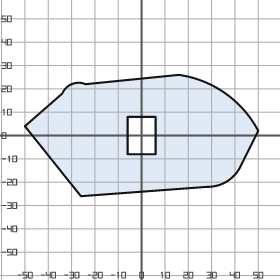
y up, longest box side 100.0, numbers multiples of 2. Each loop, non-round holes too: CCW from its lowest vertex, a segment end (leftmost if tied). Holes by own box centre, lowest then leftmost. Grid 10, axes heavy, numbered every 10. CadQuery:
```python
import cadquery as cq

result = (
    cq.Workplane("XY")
    .moveTo(-26.0, -26.0)
    .lineTo(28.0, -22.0)
    .threePointArc((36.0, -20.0), (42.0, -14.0))
    .lineTo(50.0, 2.0)
    .threePointArc((36.0, 18.0), (16.0, 26.0))
    .lineTo(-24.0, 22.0)
    .threePointArc((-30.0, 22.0), (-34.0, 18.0))
    .lineTo(-50.0, 4.0)
    .close()
    .moveTo(-6.0, -8.0)
    .lineTo(6.0, -8.0)
    .lineTo(6.0, 8.0)
    .lineTo(-6.0, 8.0)
    .close()
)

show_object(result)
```